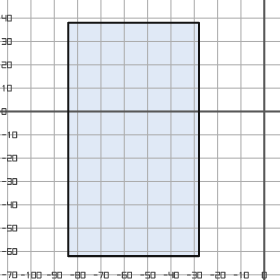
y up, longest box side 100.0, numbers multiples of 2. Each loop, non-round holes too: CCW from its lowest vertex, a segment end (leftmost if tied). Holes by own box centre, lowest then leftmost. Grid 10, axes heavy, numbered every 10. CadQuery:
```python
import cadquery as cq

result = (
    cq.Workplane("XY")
    .moveTo(-84.0, -62.0)
    .lineTo(-28.0, -62.0)
    .lineTo(-28.0, 38.0)
    .lineTo(-84.0, 38.0)
    .close()
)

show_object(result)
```